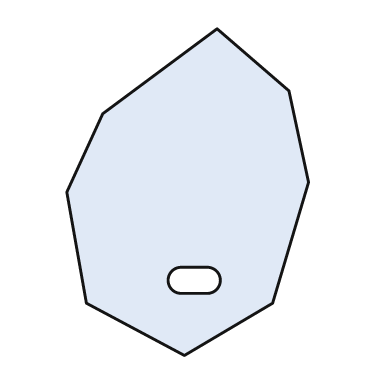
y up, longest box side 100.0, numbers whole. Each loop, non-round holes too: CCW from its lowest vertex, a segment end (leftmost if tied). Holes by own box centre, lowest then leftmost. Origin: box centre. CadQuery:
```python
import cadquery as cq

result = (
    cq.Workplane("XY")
    .moveTo(-1.0, -50.0)
    .lineTo(26.0, -34.0)
    .lineTo(37.0, 3.0)
    .lineTo(31.0, 31.0)
    .lineTo(9.0, 50.0)
    .lineTo(-26.0, 24.0)
    .lineTo(-37.0, 0.0)
    .lineTo(-31.0, -34.0)
    .close()
    .moveTo(-2.0, -31.0)
    .lineTo(6.0, -31.0)
    .threePointArc((10.0, -27.0), (6.0, -23.0))
    .lineTo(-2.0, -23.0)
    .threePointArc((-6.0, -27.0), (-2.0, -31.0))
    .close()
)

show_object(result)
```